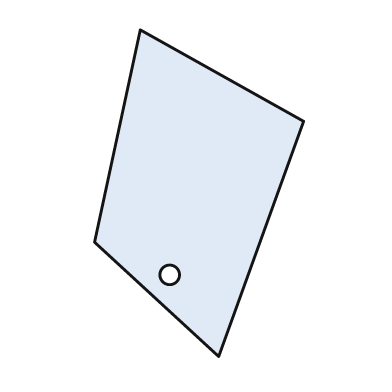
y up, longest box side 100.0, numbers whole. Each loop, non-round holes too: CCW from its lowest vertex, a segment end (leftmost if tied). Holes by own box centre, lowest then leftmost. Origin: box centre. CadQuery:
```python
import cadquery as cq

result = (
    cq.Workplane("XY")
    .moveTo(6.0, -50.0)
    .lineTo(32.0, 22.0)
    .lineTo(-18.0, 50.0)
    .lineTo(-32.0, -15.0)
    .close()
    .moveTo(-9.0, -25.0)
    .circle(3.0)
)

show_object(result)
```